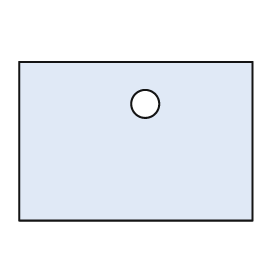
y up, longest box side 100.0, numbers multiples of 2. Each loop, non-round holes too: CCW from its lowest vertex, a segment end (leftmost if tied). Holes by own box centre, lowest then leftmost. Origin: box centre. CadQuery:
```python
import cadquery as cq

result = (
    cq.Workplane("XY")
    .moveTo(-50.0, -34.0)
    .lineTo(50.0, -34.0)
    .lineTo(50.0, 34.0)
    .lineTo(-50.0, 34.0)
    .close()
    .moveTo(4.0, 16.0)
    .circle(6.0)
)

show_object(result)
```